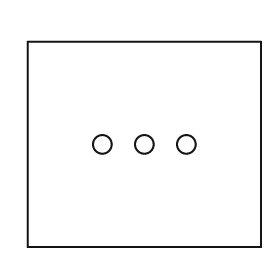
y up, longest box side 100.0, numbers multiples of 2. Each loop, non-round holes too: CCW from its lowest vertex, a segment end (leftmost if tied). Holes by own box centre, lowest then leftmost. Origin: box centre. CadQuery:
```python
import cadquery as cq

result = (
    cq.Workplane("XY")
    .moveTo(-50.0, -44.0)
    .lineTo(50.0, -44.0)
    .lineTo(50.0, 44.0)
    .lineTo(-50.0, 44.0)
    .close()
    .moveTo(-18.0, 0.0)
    .circle(4.0)
    .moveTo(0.0, 0.0)
    .circle(4.0)
    .moveTo(18.0, 0.0)
    .circle(4.0)
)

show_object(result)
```